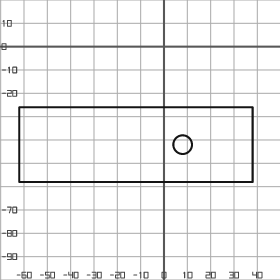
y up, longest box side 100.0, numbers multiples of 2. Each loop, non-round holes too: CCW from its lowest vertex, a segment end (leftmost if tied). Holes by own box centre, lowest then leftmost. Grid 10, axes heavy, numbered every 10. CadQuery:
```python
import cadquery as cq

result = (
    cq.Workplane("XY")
    .moveTo(-62.0, -58.0)
    .lineTo(38.0, -58.0)
    .lineTo(38.0, -26.0)
    .lineTo(-62.0, -26.0)
    .close()
    .moveTo(8.0, -42.0)
    .circle(4.0)
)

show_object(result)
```